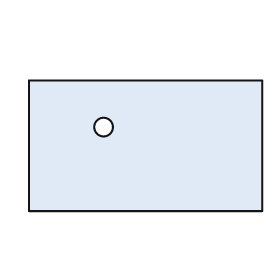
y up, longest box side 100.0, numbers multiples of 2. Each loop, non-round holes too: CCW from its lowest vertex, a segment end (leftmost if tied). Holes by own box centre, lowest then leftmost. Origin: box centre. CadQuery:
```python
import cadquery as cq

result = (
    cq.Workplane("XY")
    .moveTo(-50.0, -28.0)
    .lineTo(50.0, -28.0)
    .lineTo(50.0, 28.0)
    .lineTo(-50.0, 28.0)
    .close()
    .moveTo(-18.0, 8.0)
    .circle(4.0)
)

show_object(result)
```